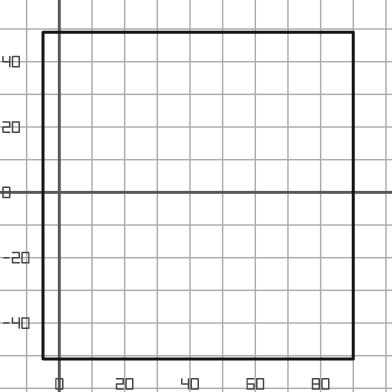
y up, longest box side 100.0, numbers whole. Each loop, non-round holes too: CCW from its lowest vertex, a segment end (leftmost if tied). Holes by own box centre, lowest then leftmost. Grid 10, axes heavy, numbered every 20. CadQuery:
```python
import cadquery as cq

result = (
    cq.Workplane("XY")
    .moveTo(-5.0, -51.0)
    .lineTo(90.0, -51.0)
    .lineTo(90.0, 49.0)
    .lineTo(-5.0, 49.0)
    .close()
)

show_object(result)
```